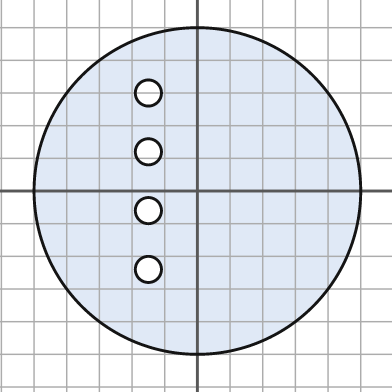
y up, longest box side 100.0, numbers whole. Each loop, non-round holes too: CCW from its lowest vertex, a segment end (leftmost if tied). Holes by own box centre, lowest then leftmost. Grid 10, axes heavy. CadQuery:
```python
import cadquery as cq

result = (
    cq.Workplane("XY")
    .moveTo(0.0, 0.0)
    .circle(50.0)
    .moveTo(-15.0, -24.0)
    .circle(4.0)
    .moveTo(-15.0, -6.0)
    .circle(4.0)
    .moveTo(-15.0, 12.0)
    .circle(4.0)
    .moveTo(-15.0, 30.0)
    .circle(4.0)
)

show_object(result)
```